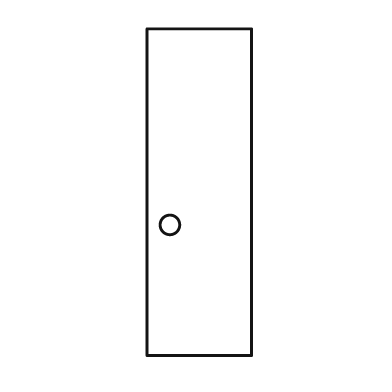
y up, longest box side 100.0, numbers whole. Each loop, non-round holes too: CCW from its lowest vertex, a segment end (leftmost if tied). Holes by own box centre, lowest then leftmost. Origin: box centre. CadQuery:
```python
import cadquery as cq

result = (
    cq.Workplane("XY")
    .moveTo(-16.0, -50.0)
    .lineTo(16.0, -50.0)
    .lineTo(16.0, 50.0)
    .lineTo(-16.0, 50.0)
    .close()
    .moveTo(-9.0, -10.0)
    .circle(3.0)
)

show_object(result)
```